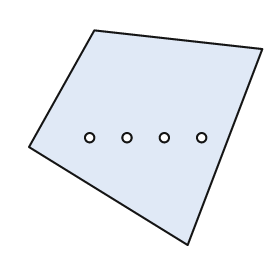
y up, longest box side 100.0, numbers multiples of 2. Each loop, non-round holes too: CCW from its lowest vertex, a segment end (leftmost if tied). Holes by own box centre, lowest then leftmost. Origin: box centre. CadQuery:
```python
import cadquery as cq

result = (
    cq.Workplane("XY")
    .moveTo(18.0, -46.0)
    .lineTo(50.0, 38.0)
    .lineTo(-22.0, 46.0)
    .lineTo(-50.0, -4.0)
    .close()
    .moveTo(-24.0, 0.0)
    .circle(2.0)
    .moveTo(-8.0, 0.0)
    .circle(2.0)
    .moveTo(8.0, 0.0)
    .circle(2.0)
    .moveTo(24.0, 0.0)
    .circle(2.0)
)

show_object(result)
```